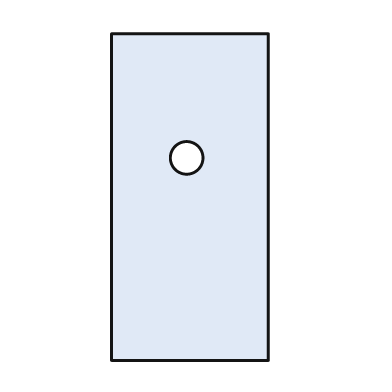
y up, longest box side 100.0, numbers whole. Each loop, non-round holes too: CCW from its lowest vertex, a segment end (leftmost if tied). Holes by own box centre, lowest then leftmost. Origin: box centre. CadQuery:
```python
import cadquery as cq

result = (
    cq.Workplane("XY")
    .moveTo(-24.0, -50.0)
    .lineTo(24.0, -50.0)
    .lineTo(24.0, 50.0)
    .lineTo(-24.0, 50.0)
    .close()
    .moveTo(-1.0, 12.0)
    .circle(5.0)
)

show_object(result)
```